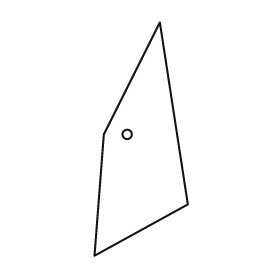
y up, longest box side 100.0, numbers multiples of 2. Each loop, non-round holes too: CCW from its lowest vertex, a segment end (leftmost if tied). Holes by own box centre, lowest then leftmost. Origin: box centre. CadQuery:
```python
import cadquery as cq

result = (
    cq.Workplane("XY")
    .moveTo(-20.0, -50.0)
    .lineTo(20.0, -28.0)
    .lineTo(8.0, 50.0)
    .lineTo(-16.0, 2.0)
    .close()
    .moveTo(-6.0, 2.0)
    .circle(2.0)
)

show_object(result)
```